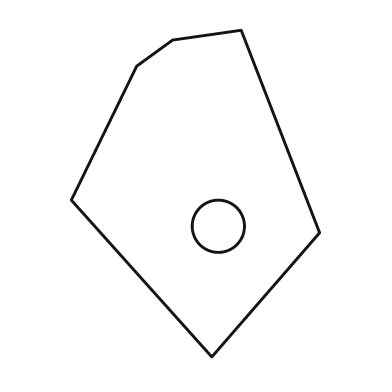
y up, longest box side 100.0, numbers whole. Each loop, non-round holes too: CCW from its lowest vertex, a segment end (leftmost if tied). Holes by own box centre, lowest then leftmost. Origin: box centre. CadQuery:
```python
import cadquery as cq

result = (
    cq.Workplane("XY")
    .moveTo(5.0, -50.0)
    .lineTo(38.0, -12.0)
    .lineTo(14.0, 50.0)
    .lineTo(-7.0, 47.0)
    .lineTo(-18.0, 39.0)
    .lineTo(-38.0, -2.0)
    .close()
    .moveTo(7.0, -10.0)
    .circle(8.0)
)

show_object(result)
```